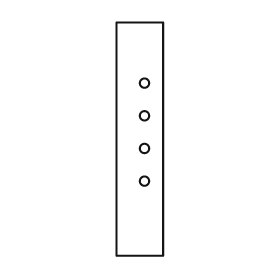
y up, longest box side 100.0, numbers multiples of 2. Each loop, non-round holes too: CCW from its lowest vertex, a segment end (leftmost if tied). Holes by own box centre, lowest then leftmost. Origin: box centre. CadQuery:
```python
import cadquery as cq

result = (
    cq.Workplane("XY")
    .moveTo(-10.0, -50.0)
    .lineTo(10.0, -50.0)
    .lineTo(10.0, 50.0)
    .lineTo(-10.0, 50.0)
    .close()
    .moveTo(2.0, -18.0)
    .circle(2.0)
    .moveTo(2.0, -4.0)
    .circle(2.0)
    .moveTo(2.0, 10.0)
    .circle(2.0)
    .moveTo(2.0, 24.0)
    .circle(2.0)
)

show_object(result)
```